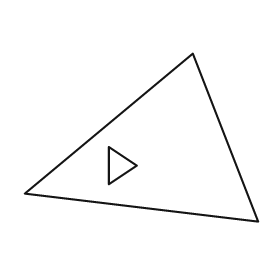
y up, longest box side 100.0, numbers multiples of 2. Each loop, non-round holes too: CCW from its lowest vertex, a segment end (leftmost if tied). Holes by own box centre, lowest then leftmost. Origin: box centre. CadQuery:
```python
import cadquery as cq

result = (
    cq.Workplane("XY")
    .moveTo(50.0, -36.0)
    .lineTo(22.0, 36.0)
    .lineTo(-50.0, -24.0)
    .close()
    .moveTo(-14.0, -20.0)
    .lineTo(-2.0, -12.0)
    .lineTo(-14.0, -4.0)
    .close()
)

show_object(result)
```